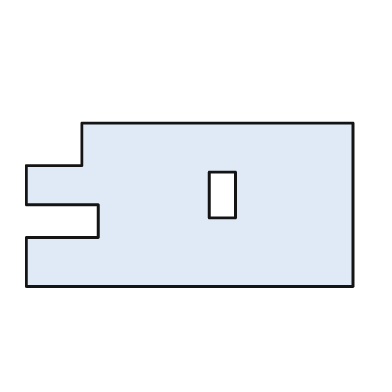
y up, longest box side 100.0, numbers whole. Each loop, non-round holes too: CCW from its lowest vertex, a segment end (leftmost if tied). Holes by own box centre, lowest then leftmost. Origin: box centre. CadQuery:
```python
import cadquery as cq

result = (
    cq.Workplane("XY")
    .moveTo(-50.0, -25.0)
    .lineTo(50.0, -25.0)
    .lineTo(50.0, 25.0)
    .lineTo(-33.0, 25.0)
    .lineTo(-33.0, 12.0)
    .lineTo(-50.0, 12.0)
    .lineTo(-50.0, 0.0)
    .lineTo(-28.0, 0.0)
    .lineTo(-28.0, -10.0)
    .lineTo(-50.0, -10.0)
    .close()
    .moveTo(6.0, -4.0)
    .lineTo(14.0, -4.0)
    .lineTo(14.0, 10.0)
    .lineTo(6.0, 10.0)
    .close()
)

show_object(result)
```